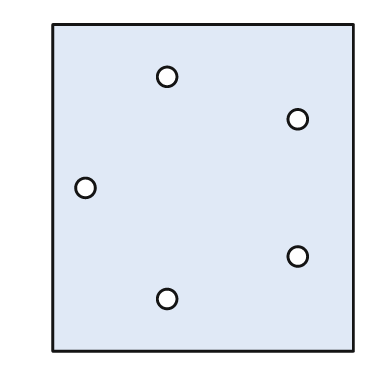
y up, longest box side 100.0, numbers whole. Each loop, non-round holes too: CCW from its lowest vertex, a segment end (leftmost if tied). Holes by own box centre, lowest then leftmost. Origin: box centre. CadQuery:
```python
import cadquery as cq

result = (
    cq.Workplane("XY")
    .moveTo(-46.0, -50.0)
    .lineTo(46.0, -50.0)
    .lineTo(46.0, 50.0)
    .lineTo(-46.0, 50.0)
    .close()
    .moveTo(-11.0, -34.0)
    .circle(3.0)
    .moveTo(29.0, -21.0)
    .circle(3.0)
    .moveTo(-36.0, 0.0)
    .circle(3.0)
    .moveTo(29.0, 21.0)
    .circle(3.0)
    .moveTo(-11.0, 34.0)
    .circle(3.0)
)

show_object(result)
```